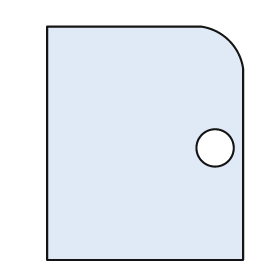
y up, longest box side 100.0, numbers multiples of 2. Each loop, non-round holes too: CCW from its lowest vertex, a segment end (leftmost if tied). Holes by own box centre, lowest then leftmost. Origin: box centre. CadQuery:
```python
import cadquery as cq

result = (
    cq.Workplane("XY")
    .moveTo(-42.0, -50.0)
    .lineTo(42.0, -50.0)
    .lineTo(42.0, 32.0)
    .threePointArc((36.0, 44.0), (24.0, 50.0))
    .lineTo(-42.0, 50.0)
    .close()
    .moveTo(30.0, -2.0)
    .circle(8.0)
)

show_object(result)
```